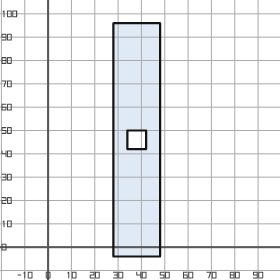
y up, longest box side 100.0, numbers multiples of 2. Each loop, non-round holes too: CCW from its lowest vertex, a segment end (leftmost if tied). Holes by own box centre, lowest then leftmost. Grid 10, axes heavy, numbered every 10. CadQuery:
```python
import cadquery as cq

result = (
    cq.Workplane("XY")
    .moveTo(28.0, -4.0)
    .lineTo(48.0, -4.0)
    .lineTo(48.0, 96.0)
    .lineTo(28.0, 96.0)
    .close()
    .moveTo(34.0, 42.0)
    .lineTo(42.0, 42.0)
    .lineTo(42.0, 50.0)
    .lineTo(34.0, 50.0)
    .close()
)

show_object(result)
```